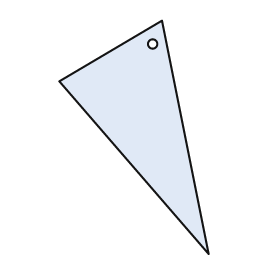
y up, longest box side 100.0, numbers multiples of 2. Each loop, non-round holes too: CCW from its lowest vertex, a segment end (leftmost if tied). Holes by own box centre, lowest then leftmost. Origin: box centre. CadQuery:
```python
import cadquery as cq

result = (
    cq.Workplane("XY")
    .moveTo(32.0, -50.0)
    .lineTo(12.0, 50.0)
    .lineTo(-32.0, 24.0)
    .close()
    .moveTo(8.0, 40.0)
    .circle(2.0)
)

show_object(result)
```